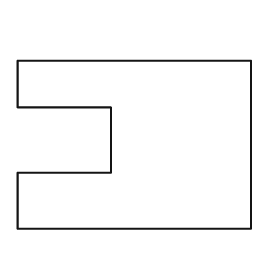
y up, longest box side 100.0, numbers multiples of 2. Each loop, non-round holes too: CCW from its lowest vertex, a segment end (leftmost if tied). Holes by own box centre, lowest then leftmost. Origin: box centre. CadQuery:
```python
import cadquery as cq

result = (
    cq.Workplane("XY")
    .moveTo(-50.0, -36.0)
    .lineTo(50.0, -36.0)
    .lineTo(50.0, 36.0)
    .lineTo(-50.0, 36.0)
    .lineTo(-50.0, 16.0)
    .lineTo(-10.0, 16.0)
    .lineTo(-10.0, -12.0)
    .lineTo(-50.0, -12.0)
    .close()
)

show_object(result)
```